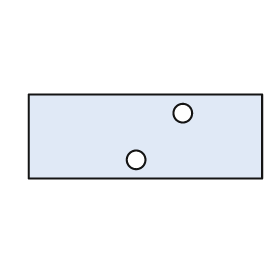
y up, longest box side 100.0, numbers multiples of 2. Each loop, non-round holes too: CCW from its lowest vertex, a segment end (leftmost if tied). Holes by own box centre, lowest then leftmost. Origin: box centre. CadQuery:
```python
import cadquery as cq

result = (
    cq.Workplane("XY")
    .moveTo(-50.0, -18.0)
    .lineTo(50.0, -18.0)
    .lineTo(50.0, 18.0)
    .lineTo(-50.0, 18.0)
    .close()
    .moveTo(-4.0, -10.0)
    .circle(4.0)
    .moveTo(16.0, 10.0)
    .circle(4.0)
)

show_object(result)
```